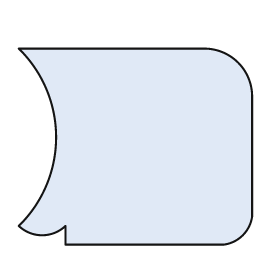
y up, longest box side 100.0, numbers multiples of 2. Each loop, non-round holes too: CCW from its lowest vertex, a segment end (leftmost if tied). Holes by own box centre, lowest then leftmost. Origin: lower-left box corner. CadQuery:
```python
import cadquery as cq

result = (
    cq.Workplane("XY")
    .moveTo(20.0, 0.0)
    .lineTo(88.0, 0.0)
    .threePointArc((96.0, 4.0), (100.0, 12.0))
    .lineTo(100.0, 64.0)
    .threePointArc((94.0, 78.0), (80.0, 84.0))
    .lineTo(0.0, 84.0)
    .threePointArc((16.0, 46.0), (0.0, 8.0))
    .threePointArc((10.0, 4.0), (20.0, 8.0))
    .close()
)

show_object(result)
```